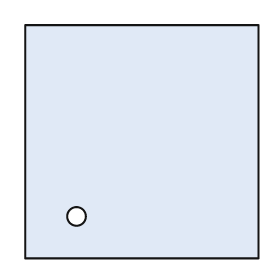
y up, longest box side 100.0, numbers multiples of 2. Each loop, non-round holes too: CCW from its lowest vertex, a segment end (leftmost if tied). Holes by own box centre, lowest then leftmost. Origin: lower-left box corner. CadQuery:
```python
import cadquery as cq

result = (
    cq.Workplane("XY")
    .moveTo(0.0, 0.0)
    .lineTo(100.0, 0.0)
    .lineTo(100.0, 100.0)
    .lineTo(0.0, 100.0)
    .close()
    .moveTo(22.0, 18.0)
    .circle(4.0)
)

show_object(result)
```